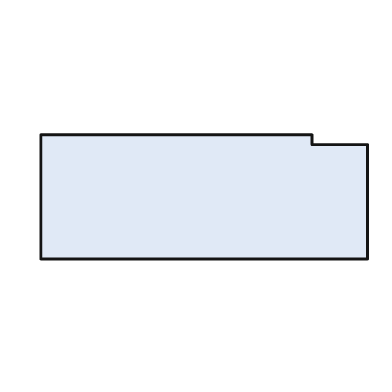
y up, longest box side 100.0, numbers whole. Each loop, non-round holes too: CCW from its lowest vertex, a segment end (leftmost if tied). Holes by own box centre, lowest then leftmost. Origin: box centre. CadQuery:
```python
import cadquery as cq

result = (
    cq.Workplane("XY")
    .moveTo(-50.0, -19.0)
    .lineTo(50.0, -19.0)
    .lineTo(50.0, 16.0)
    .lineTo(33.0, 16.0)
    .lineTo(33.0, 19.0)
    .lineTo(-50.0, 19.0)
    .close()
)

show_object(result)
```